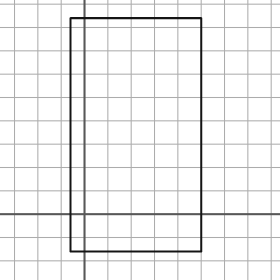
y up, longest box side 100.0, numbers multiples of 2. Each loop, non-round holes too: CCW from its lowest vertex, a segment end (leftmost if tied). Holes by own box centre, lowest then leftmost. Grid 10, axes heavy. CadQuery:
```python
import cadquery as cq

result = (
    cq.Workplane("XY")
    .moveTo(-6.0, -16.0)
    .lineTo(50.0, -16.0)
    .lineTo(50.0, 84.0)
    .lineTo(-6.0, 84.0)
    .close()
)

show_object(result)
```